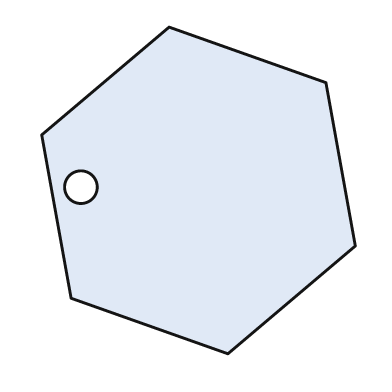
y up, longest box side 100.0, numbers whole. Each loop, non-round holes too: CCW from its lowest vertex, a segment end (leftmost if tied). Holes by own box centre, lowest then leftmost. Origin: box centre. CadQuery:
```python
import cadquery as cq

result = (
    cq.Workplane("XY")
    .moveTo(9.0, -50.0)
    .lineTo(48.0, -17.0)
    .lineTo(39.0, 33.0)
    .lineTo(-9.0, 50.0)
    .lineTo(-48.0, 17.0)
    .lineTo(-39.0, -33.0)
    .close()
    .moveTo(-36.0, 1.0)
    .circle(5.0)
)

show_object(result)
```